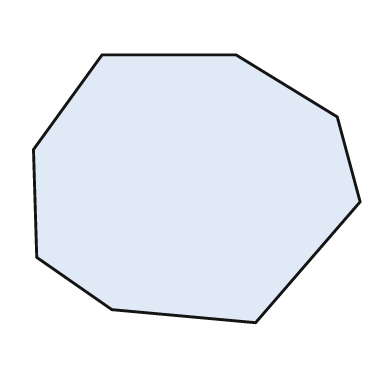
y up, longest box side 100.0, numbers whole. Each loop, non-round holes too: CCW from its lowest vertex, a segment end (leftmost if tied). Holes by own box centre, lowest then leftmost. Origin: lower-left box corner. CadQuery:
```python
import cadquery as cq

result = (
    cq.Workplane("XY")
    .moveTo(68.0, 0.0)
    .lineTo(100.0, 37.0)
    .lineTo(93.0, 63.0)
    .lineTo(62.0, 82.0)
    .lineTo(21.0, 82.0)
    .lineTo(0.0, 53.0)
    .lineTo(1.0, 20.0)
    .lineTo(24.0, 4.0)
    .close()
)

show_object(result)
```